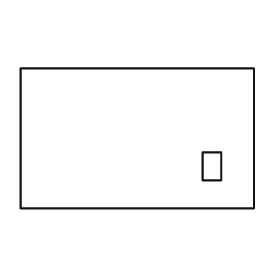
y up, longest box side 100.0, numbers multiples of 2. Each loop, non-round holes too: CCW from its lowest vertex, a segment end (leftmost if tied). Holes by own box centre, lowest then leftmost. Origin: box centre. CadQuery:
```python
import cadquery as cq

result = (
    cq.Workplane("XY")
    .moveTo(-50.0, -30.0)
    .lineTo(50.0, -30.0)
    .lineTo(50.0, 30.0)
    .lineTo(-50.0, 30.0)
    .close()
    .moveTo(28.0, -18.0)
    .lineTo(36.0, -18.0)
    .lineTo(36.0, -6.0)
    .lineTo(28.0, -6.0)
    .close()
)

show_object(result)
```